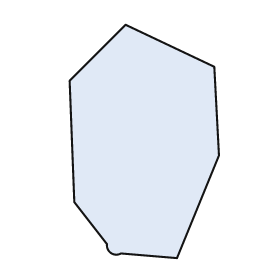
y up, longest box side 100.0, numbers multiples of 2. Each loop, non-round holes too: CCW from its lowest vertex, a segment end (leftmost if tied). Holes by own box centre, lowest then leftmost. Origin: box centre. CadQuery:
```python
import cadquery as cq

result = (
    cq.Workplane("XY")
    .moveTo(14.0, -50.0)
    .lineTo(32.0, -6.0)
    .lineTo(30.0, 32.0)
    .lineTo(-8.0, 50.0)
    .lineTo(-32.0, 26.0)
    .lineTo(-30.0, -26.0)
    .lineTo(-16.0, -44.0)
    .threePointArc((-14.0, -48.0), (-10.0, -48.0))
    .close()
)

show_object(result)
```